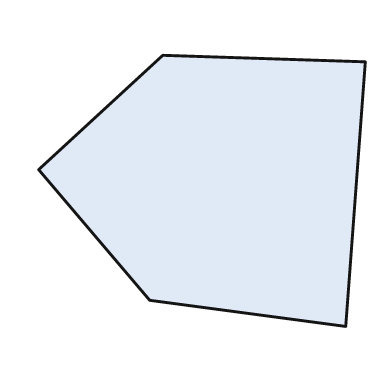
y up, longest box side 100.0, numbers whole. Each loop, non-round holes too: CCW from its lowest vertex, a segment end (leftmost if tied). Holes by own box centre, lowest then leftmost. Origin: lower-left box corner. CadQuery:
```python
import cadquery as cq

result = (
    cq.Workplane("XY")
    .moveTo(94.0, 0.0)
    .lineTo(100.0, 81.0)
    .lineTo(38.0, 83.0)
    .lineTo(0.0, 48.0)
    .lineTo(34.0, 8.0)
    .close()
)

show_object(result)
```